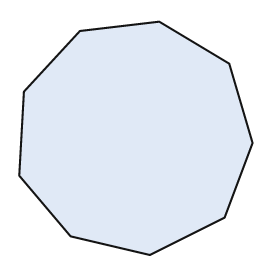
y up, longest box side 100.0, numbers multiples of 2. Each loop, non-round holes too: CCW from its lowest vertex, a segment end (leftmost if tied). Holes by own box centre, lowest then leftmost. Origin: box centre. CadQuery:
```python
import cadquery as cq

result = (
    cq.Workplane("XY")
    .moveTo(6.0, -50.0)
    .lineTo(38.0, -34.0)
    .lineTo(50.0, -2.0)
    .lineTo(40.0, 32.0)
    .lineTo(10.0, 50.0)
    .lineTo(-24.0, 46.0)
    .lineTo(-48.0, 20.0)
    .lineTo(-50.0, -16.0)
    .lineTo(-28.0, -42.0)
    .close()
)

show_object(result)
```